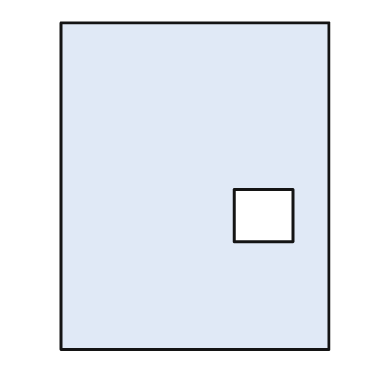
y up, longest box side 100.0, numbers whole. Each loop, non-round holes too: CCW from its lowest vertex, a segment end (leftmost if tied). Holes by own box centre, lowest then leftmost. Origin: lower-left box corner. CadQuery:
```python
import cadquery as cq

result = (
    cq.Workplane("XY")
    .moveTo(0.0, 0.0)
    .lineTo(82.0, 0.0)
    .lineTo(82.0, 100.0)
    .lineTo(0.0, 100.0)
    .close()
    .moveTo(53.0, 33.0)
    .lineTo(71.0, 33.0)
    .lineTo(71.0, 49.0)
    .lineTo(53.0, 49.0)
    .close()
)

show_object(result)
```